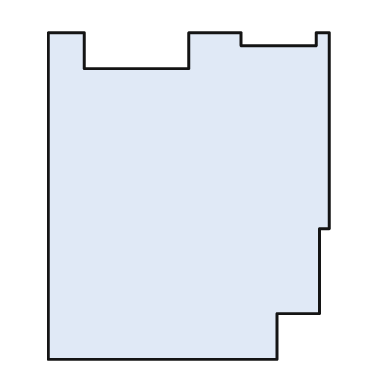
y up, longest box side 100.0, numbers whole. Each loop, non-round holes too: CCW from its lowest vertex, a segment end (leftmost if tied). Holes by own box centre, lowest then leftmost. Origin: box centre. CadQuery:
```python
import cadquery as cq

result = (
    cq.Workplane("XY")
    .moveTo(-43.0, -50.0)
    .lineTo(27.0, -50.0)
    .lineTo(27.0, -36.0)
    .lineTo(40.0, -36.0)
    .lineTo(40.0, -10.0)
    .lineTo(43.0, -10.0)
    .lineTo(43.0, 50.0)
    .lineTo(39.0, 50.0)
    .lineTo(39.0, 46.0)
    .lineTo(16.0, 46.0)
    .lineTo(16.0, 50.0)
    .lineTo(0.0, 50.0)
    .lineTo(0.0, 39.0)
    .lineTo(-32.0, 39.0)
    .lineTo(-32.0, 50.0)
    .lineTo(-43.0, 50.0)
    .close()
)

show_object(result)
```